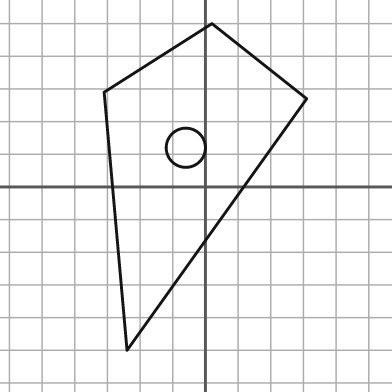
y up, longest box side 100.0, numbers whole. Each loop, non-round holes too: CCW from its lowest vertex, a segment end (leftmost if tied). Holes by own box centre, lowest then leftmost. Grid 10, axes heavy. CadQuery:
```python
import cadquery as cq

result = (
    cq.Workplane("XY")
    .moveTo(-24.0, -50.0)
    .lineTo(31.0, 27.0)
    .lineTo(2.0, 50.0)
    .lineTo(-31.0, 29.0)
    .close()
    .moveTo(-6.0, 12.0)
    .circle(6.0)
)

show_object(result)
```